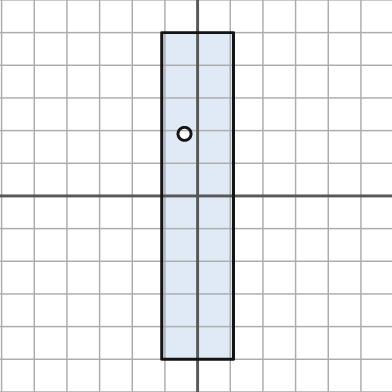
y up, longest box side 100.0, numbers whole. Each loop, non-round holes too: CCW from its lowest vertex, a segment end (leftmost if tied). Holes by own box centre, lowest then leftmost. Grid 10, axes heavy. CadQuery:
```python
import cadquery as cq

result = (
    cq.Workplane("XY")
    .moveTo(-11.0, -50.0)
    .lineTo(11.0, -50.0)
    .lineTo(11.0, 50.0)
    .lineTo(-11.0, 50.0)
    .close()
    .moveTo(-4.0, 19.0)
    .circle(2.0)
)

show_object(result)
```